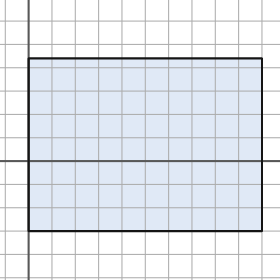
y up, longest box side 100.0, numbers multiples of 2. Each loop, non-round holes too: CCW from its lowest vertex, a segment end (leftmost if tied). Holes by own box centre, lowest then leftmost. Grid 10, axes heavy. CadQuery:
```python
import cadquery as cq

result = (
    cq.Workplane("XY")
    .moveTo(0.0, -30.0)
    .lineTo(100.0, -30.0)
    .lineTo(100.0, 44.0)
    .lineTo(0.0, 44.0)
    .close()
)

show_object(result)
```